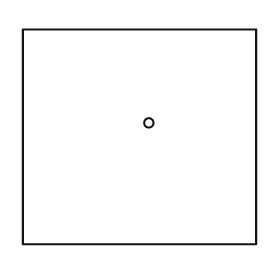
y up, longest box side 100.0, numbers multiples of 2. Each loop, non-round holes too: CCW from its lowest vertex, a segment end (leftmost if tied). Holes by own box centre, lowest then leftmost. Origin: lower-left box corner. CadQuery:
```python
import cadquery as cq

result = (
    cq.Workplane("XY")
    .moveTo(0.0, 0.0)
    .lineTo(100.0, 0.0)
    .lineTo(100.0, 92.0)
    .lineTo(0.0, 92.0)
    .close()
    .moveTo(54.0, 52.0)
    .circle(2.0)
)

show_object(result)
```